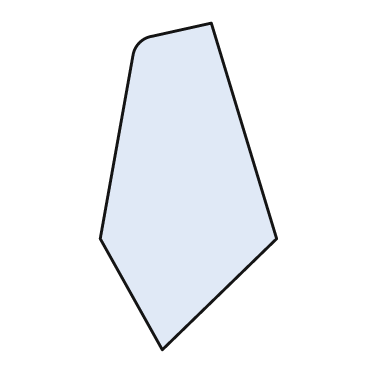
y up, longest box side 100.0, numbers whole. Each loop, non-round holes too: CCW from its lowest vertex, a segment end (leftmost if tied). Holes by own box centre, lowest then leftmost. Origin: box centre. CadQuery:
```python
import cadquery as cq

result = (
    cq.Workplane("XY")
    .moveTo(-8.0, -50.0)
    .lineTo(27.0, -16.0)
    .lineTo(7.0, 50.0)
    .lineTo(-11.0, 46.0)
    .threePointArc((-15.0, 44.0), (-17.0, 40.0))
    .lineTo(-27.0, -16.0)
    .close()
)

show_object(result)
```